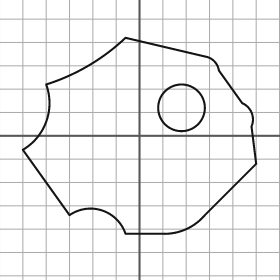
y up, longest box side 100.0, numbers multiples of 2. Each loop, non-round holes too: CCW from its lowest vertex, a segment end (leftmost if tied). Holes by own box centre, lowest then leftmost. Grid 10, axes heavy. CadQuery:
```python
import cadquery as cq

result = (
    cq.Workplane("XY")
    .moveTo(-6.0, -42.0)
    .lineTo(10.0, -42.0)
    .threePointArc((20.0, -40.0), (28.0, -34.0))
    .lineTo(50.0, -12.0)
    .lineTo(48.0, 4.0)
    .threePointArc((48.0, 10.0), (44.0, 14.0))
    .lineTo(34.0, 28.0)
    .threePointArc((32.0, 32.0), (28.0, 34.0))
    .lineTo(-6.0, 42.0)
    .threePointArc((-22.0, 30.0), (-40.0, 22.0))
    .threePointArc((-40.0, 6.0), (-50.0, -6.0))
    .lineTo(-30.0, -34.0)
    .threePointArc((-16.0, -32.0), (-6.0, -42.0))
    .close()
    .moveTo(18.0, 12.0)
    .circle(10.0)
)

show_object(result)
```